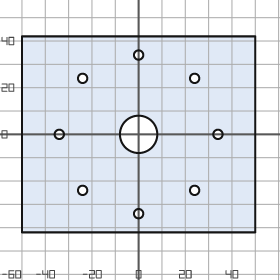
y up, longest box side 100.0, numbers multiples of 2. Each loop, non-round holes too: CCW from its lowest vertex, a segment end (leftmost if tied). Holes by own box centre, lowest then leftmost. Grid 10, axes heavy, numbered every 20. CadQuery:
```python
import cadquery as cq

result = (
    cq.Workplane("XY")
    .moveTo(-50.0, -42.0)
    .lineTo(50.0, -42.0)
    .lineTo(50.0, 42.0)
    .lineTo(-50.0, 42.0)
    .close()
    .moveTo(0.0, -34.0)
    .circle(2.0)
    .moveTo(-24.0, -24.0)
    .circle(2.0)
    .moveTo(24.0, -24.0)
    .circle(2.0)
    .moveTo(-34.0, 0.0)
    .circle(2.0)
    .moveTo(0.0, 0.0)
    .circle(8.0)
    .moveTo(34.0, 0.0)
    .circle(2.0)
    .moveTo(-24.0, 24.0)
    .circle(2.0)
    .moveTo(24.0, 24.0)
    .circle(2.0)
    .moveTo(0.0, 34.0)
    .circle(2.0)
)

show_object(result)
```